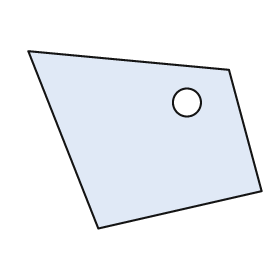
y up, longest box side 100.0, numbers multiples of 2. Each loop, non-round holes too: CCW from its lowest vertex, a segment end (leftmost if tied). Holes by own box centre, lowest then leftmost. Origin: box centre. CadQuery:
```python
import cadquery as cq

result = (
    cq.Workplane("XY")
    .moveTo(-20.0, -38.0)
    .lineTo(50.0, -22.0)
    .lineTo(36.0, 30.0)
    .lineTo(-50.0, 38.0)
    .close()
    .moveTo(18.0, 16.0)
    .circle(6.0)
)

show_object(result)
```